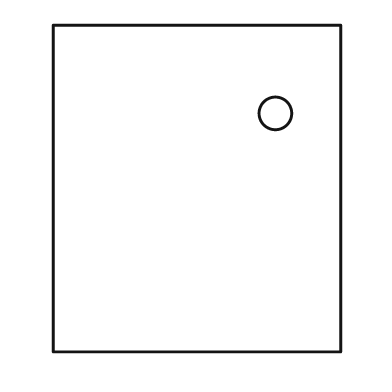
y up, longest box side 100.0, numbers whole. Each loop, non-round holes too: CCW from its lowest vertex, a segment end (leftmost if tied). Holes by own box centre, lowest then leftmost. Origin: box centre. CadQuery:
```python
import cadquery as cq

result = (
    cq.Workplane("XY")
    .moveTo(-44.0, -50.0)
    .lineTo(44.0, -50.0)
    .lineTo(44.0, 50.0)
    .lineTo(-44.0, 50.0)
    .close()
    .moveTo(24.0, 23.0)
    .circle(5.0)
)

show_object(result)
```